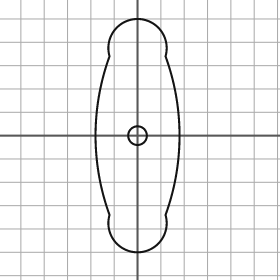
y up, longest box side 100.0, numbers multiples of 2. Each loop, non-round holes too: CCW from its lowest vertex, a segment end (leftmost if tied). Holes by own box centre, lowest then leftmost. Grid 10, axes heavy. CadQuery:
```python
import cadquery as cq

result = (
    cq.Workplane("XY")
    .moveTo(-12.0, -34.0)
    .threePointArc((0.0, -50.0), (12.0, -34.0))
    .threePointArc((18.0, 0.0), (12.0, 34.0))
    .threePointArc((0.0, 50.0), (-12.0, 34.0))
    .threePointArc((-18.0, 0.0), (-12.0, -34.0))
    .close()
    .moveTo(0.0, 0.0)
    .circle(4.0)
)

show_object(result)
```